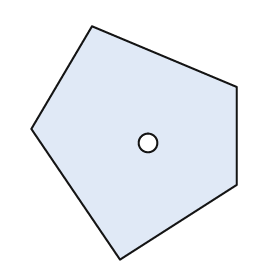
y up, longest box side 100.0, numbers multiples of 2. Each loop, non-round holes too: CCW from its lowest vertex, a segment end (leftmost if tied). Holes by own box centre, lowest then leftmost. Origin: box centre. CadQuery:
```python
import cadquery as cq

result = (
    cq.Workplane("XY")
    .moveTo(-6.0, -50.0)
    .lineTo(44.0, -18.0)
    .lineTo(44.0, 24.0)
    .lineTo(-18.0, 50.0)
    .lineTo(-44.0, 6.0)
    .close()
    .moveTo(6.0, 0.0)
    .circle(4.0)
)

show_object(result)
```